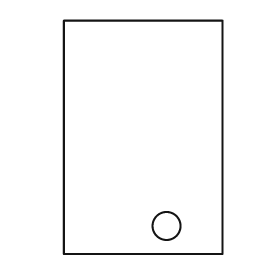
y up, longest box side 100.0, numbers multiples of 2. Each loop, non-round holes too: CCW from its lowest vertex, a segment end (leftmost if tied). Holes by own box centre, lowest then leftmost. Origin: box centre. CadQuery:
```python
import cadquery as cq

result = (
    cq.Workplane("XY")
    .moveTo(-34.0, -50.0)
    .lineTo(34.0, -50.0)
    .lineTo(34.0, 50.0)
    .lineTo(-34.0, 50.0)
    .close()
    .moveTo(10.0, -38.0)
    .circle(6.0)
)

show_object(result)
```